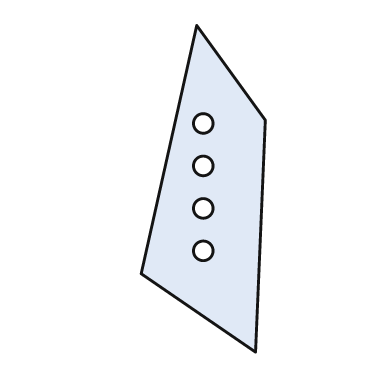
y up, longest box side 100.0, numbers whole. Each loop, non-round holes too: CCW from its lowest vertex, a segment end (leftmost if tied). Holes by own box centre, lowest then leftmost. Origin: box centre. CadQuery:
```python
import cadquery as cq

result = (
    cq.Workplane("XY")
    .moveTo(16.0, -50.0)
    .lineTo(19.0, 21.0)
    .lineTo(-2.0, 50.0)
    .lineTo(-19.0, -26.0)
    .close()
    .moveTo(0.0, -19.0)
    .circle(3.0)
    .moveTo(0.0, -6.0)
    .circle(3.0)
    .moveTo(0.0, 7.0)
    .circle(3.0)
    .moveTo(0.0, 20.0)
    .circle(3.0)
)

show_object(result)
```